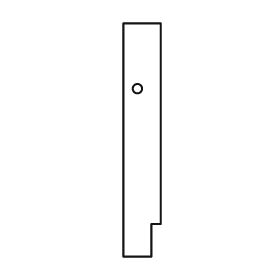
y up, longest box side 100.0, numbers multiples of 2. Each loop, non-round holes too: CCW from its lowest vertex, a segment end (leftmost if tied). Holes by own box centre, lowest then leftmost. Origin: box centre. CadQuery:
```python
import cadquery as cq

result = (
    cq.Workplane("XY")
    .moveTo(-8.0, -50.0)
    .lineTo(4.0, -50.0)
    .lineTo(4.0, -36.0)
    .lineTo(8.0, -36.0)
    .lineTo(8.0, 50.0)
    .lineTo(-8.0, 50.0)
    .close()
    .moveTo(-2.0, 22.0)
    .circle(2.0)
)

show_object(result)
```